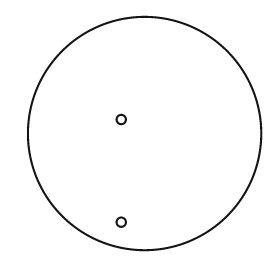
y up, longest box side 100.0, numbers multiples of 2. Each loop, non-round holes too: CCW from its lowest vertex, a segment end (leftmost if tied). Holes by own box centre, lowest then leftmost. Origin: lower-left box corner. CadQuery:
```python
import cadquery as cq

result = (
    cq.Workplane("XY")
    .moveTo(50.0, 50.0)
    .circle(50.0)
    .moveTo(40.0, 12.0)
    .circle(2.0)
    .moveTo(40.0, 56.0)
    .circle(2.0)
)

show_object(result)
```